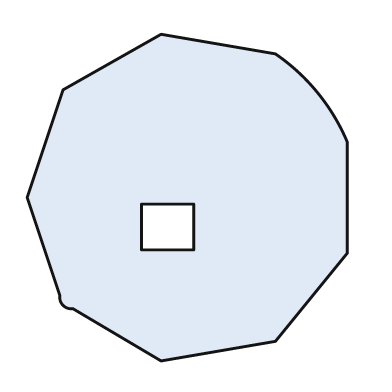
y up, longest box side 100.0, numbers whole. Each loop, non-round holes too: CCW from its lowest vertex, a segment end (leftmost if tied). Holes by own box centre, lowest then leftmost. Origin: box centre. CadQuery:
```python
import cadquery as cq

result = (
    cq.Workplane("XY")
    .moveTo(-8.0, -50.0)
    .lineTo(27.0, -44.0)
    .lineTo(49.0, -17.0)
    .lineTo(49.0, 17.0)
    .threePointArc((40.0, 32.0), (27.0, 44.0))
    .lineTo(-8.0, 50.0)
    .lineTo(-38.0, 33.0)
    .lineTo(-49.0, 0.0)
    .lineTo(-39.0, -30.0)
    .threePointArc((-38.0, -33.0), (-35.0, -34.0))
    .close()
    .moveTo(-14.0, -16.0)
    .lineTo(2.0, -16.0)
    .lineTo(2.0, -2.0)
    .lineTo(-14.0, -2.0)
    .close()
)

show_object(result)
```